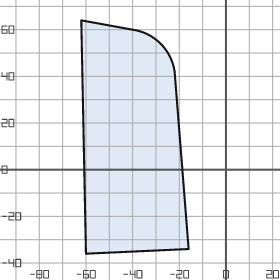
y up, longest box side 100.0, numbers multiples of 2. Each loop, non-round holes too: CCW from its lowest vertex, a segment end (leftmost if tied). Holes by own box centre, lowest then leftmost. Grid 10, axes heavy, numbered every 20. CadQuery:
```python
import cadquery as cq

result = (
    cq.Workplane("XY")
    .moveTo(-60.0, -36.0)
    .lineTo(-16.0, -34.0)
    .lineTo(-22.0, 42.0)
    .threePointArc((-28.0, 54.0), (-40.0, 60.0))
    .lineTo(-62.0, 64.0)
    .close()
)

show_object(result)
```